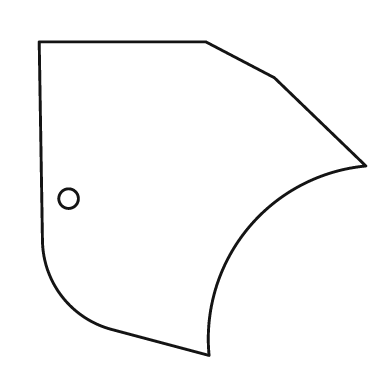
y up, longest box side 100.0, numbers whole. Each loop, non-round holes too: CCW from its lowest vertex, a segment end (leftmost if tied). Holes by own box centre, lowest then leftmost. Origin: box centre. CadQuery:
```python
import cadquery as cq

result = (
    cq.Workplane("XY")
    .moveTo(2.0, -48.0)
    .threePointArc((14.0, -9.0), (50.0, 10.0))
    .lineTo(22.0, 37.0)
    .lineTo(1.0, 48.0)
    .lineTo(-50.0, 48.0)
    .lineTo(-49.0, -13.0)
    .threePointArc((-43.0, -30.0), (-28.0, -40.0))
    .close()
    .moveTo(-41.0, 0.0)
    .circle(3.0)
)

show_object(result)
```